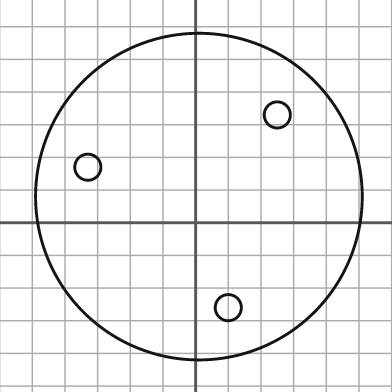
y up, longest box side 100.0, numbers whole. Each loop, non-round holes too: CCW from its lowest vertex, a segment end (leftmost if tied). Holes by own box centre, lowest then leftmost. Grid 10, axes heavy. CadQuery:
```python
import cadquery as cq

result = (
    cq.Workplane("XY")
    .moveTo(1.0, 8.0)
    .circle(50.0)
    .moveTo(10.0, -26.0)
    .circle(4.0)
    .moveTo(-33.0, 17.0)
    .circle(4.0)
    .moveTo(25.0, 33.0)
    .circle(4.0)
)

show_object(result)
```